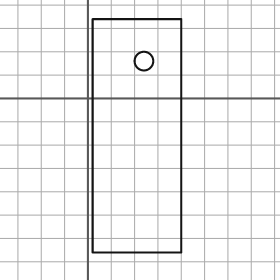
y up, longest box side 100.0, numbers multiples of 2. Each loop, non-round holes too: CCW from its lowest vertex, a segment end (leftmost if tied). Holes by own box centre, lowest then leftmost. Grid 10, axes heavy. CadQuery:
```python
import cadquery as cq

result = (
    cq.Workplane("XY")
    .moveTo(2.0, -66.0)
    .lineTo(40.0, -66.0)
    .lineTo(40.0, 34.0)
    .lineTo(2.0, 34.0)
    .close()
    .moveTo(24.0, 16.0)
    .circle(4.0)
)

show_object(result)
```